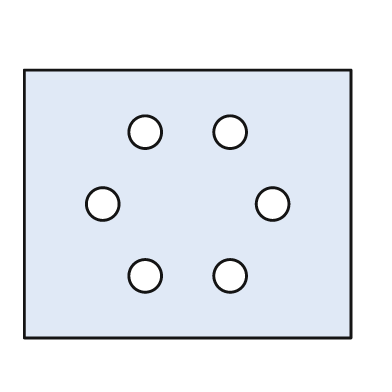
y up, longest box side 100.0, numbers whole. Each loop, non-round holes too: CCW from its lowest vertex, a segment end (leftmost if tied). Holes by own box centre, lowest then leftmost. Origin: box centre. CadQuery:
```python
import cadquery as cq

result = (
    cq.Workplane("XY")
    .moveTo(-50.0, -41.0)
    .lineTo(50.0, -41.0)
    .lineTo(50.0, 41.0)
    .lineTo(-50.0, 41.0)
    .close()
    .moveTo(-13.0, -22.0)
    .circle(5.0)
    .moveTo(13.0, -22.0)
    .circle(5.0)
    .moveTo(-26.0, 0.0)
    .circle(5.0)
    .moveTo(26.0, 0.0)
    .circle(5.0)
    .moveTo(-13.0, 22.0)
    .circle(5.0)
    .moveTo(13.0, 22.0)
    .circle(5.0)
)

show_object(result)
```